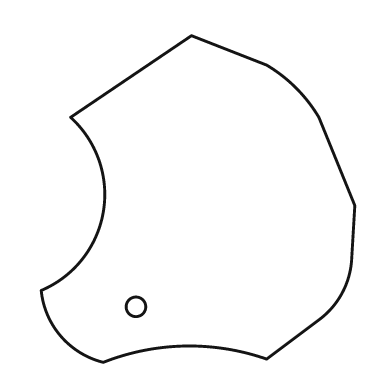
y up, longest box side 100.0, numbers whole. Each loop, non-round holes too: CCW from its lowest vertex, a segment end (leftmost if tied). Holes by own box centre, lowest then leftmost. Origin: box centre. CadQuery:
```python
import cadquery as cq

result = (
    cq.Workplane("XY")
    .moveTo(-29.0, -50.0)
    .threePointArc((-4.0, -45.0), (21.0, -49.0))
    .lineTo(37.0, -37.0)
    .threePointArc((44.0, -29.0), (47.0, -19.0))
    .lineTo(48.0, -2.0)
    .lineTo(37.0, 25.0)
    .threePointArc((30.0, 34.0), (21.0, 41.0))
    .lineTo(-2.0, 50.0)
    .lineTo(-39.0, 25.0)
    .threePointArc((-29.0, -4.0), (-48.0, -28.0))
    .threePointArc((-42.0, -42.0), (-29.0, -50.0))
    .close()
    .moveTo(-19.0, -33.0)
    .circle(3.0)
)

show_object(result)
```